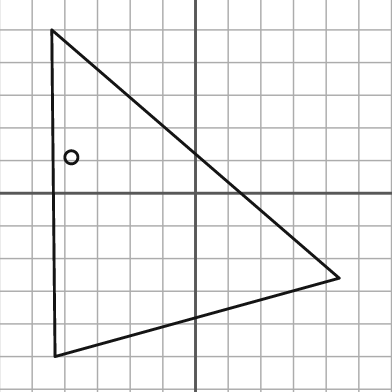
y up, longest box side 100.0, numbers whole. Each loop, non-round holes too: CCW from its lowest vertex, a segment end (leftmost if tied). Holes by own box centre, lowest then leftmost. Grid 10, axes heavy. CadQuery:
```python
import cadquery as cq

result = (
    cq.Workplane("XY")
    .moveTo(-43.0, -50.0)
    .lineTo(44.0, -26.0)
    .lineTo(-44.0, 50.0)
    .close()
    .moveTo(-38.0, 11.0)
    .circle(2.0)
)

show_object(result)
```